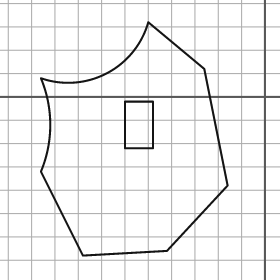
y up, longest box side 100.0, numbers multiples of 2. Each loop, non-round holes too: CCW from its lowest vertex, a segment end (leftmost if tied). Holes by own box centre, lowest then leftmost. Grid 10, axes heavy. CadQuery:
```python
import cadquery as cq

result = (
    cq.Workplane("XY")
    .moveTo(-78.0, -68.0)
    .lineTo(-42.0, -66.0)
    .lineTo(-16.0, -38.0)
    .lineTo(-26.0, 12.0)
    .lineTo(-50.0, 32.0)
    .threePointArc((-68.0, 10.0), (-96.0, 8.0))
    .threePointArc((-92.0, -12.0), (-96.0, -32.0))
    .close()
    .moveTo(-60.0, -22.0)
    .lineTo(-48.0, -22.0)
    .lineTo(-48.0, -2.0)
    .lineTo(-60.0, -2.0)
    .close()
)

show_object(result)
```